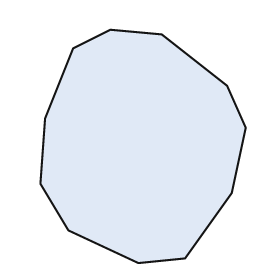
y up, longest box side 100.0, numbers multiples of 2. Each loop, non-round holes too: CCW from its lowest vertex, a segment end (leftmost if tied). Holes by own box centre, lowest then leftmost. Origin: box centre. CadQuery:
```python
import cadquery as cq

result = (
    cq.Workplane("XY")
    .moveTo(-2.0, -50.0)
    .lineTo(18.0, -48.0)
    .lineTo(38.0, -20.0)
    .lineTo(44.0, 8.0)
    .lineTo(36.0, 26.0)
    .lineTo(8.0, 48.0)
    .lineTo(-14.0, 50.0)
    .lineTo(-30.0, 42.0)
    .lineTo(-42.0, 12.0)
    .lineTo(-44.0, -16.0)
    .lineTo(-32.0, -36.0)
    .close()
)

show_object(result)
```